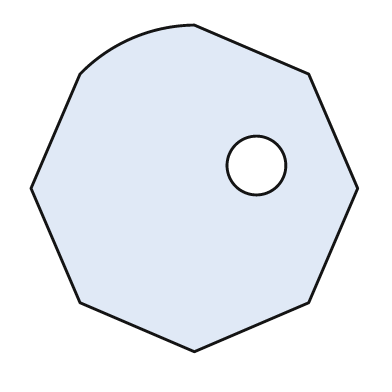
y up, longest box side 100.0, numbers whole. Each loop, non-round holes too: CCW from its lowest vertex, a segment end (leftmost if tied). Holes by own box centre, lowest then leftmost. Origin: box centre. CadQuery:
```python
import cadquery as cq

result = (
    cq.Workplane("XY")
    .moveTo(0.0, -50.0)
    .lineTo(35.0, -35.0)
    .lineTo(50.0, 0.0)
    .lineTo(35.0, 35.0)
    .lineTo(0.0, 50.0)
    .threePointArc((-19.0, 46.0), (-35.0, 35.0))
    .lineTo(-50.0, 0.0)
    .lineTo(-35.0, -35.0)
    .close()
    .moveTo(19.0, 7.0)
    .circle(9.0)
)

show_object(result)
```